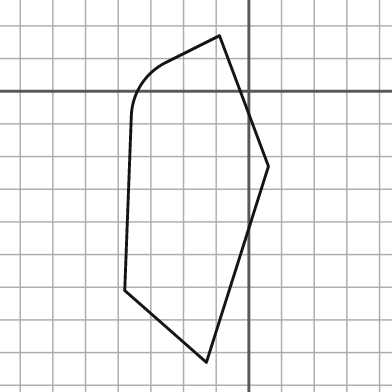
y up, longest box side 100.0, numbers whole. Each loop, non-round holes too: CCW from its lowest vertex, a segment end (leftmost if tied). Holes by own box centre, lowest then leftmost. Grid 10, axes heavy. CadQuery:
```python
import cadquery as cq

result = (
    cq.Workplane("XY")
    .moveTo(-13.0, -83.0)
    .lineTo(6.0, -23.0)
    .lineTo(-9.0, 17.0)
    .lineTo(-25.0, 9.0)
    .threePointArc((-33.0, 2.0), (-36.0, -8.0))
    .lineTo(-38.0, -61.0)
    .close()
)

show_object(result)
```